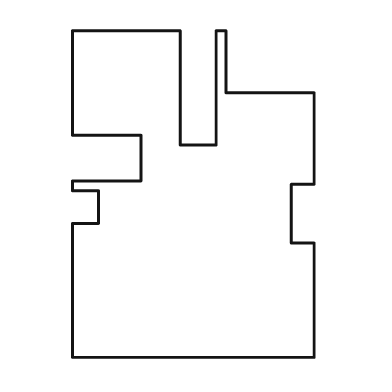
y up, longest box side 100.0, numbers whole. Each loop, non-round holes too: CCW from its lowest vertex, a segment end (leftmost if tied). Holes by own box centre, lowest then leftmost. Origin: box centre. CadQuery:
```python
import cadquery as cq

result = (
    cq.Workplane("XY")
    .moveTo(-37.0, -50.0)
    .lineTo(37.0, -50.0)
    .lineTo(37.0, -15.0)
    .lineTo(30.0, -15.0)
    .lineTo(30.0, 3.0)
    .lineTo(37.0, 3.0)
    .lineTo(37.0, 31.0)
    .lineTo(10.0, 31.0)
    .lineTo(10.0, 50.0)
    .lineTo(7.0, 50.0)
    .lineTo(7.0, 15.0)
    .lineTo(-4.0, 15.0)
    .lineTo(-4.0, 50.0)
    .lineTo(-37.0, 50.0)
    .lineTo(-37.0, 18.0)
    .lineTo(-16.0, 18.0)
    .lineTo(-16.0, 4.0)
    .lineTo(-37.0, 4.0)
    .lineTo(-37.0, 1.0)
    .lineTo(-29.0, 1.0)
    .lineTo(-29.0, -9.0)
    .lineTo(-37.0, -9.0)
    .close()
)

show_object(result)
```